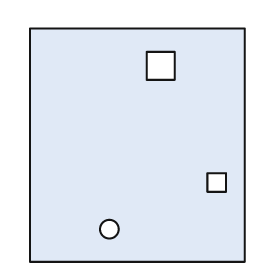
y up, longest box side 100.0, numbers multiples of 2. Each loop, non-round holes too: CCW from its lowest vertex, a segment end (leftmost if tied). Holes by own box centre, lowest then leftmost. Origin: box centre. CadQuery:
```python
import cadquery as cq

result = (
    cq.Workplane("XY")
    .moveTo(-46.0, -50.0)
    .lineTo(46.0, -50.0)
    .lineTo(46.0, 50.0)
    .lineTo(-46.0, 50.0)
    .close()
    .moveTo(-12.0, -36.0)
    .circle(4.0)
    .moveTo(30.0, -20.0)
    .lineTo(38.0, -20.0)
    .lineTo(38.0, -12.0)
    .lineTo(30.0, -12.0)
    .close()
    .moveTo(4.0, 28.0)
    .lineTo(16.0, 28.0)
    .lineTo(16.0, 40.0)
    .lineTo(4.0, 40.0)
    .close()
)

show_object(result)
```